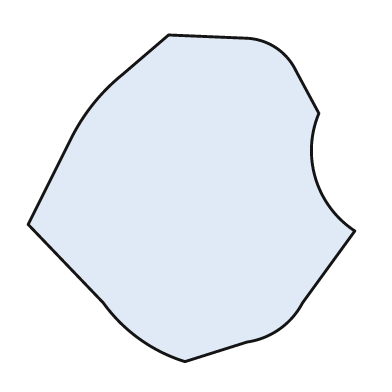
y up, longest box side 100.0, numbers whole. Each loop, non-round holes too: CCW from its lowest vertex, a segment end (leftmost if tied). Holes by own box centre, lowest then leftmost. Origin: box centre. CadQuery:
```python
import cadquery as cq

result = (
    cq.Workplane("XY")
    .moveTo(-2.0, -50.0)
    .lineTo(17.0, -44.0)
    .threePointArc((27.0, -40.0), (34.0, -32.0))
    .lineTo(50.0, -10.0)
    .threePointArc((38.0, 6.0), (39.0, 26.0))
    .lineTo(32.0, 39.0)
    .threePointArc((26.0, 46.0), (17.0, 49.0))
    .lineTo(-7.0, 50.0)
    .lineTo(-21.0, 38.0)
    .threePointArc((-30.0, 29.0), (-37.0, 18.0))
    .lineTo(-50.0, -8.0)
    .lineTo(-27.0, -32.0)
    .threePointArc((-16.0, -43.0), (-2.0, -50.0))
    .close()
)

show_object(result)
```